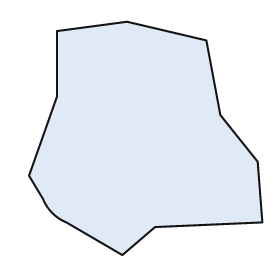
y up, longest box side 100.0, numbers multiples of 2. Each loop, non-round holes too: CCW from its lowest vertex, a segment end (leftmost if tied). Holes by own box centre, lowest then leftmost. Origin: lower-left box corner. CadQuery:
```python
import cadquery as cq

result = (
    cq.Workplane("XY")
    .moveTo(40.0, 0.0)
    .lineTo(54.0, 12.0)
    .lineTo(100.0, 14.0)
    .lineTo(98.0, 40.0)
    .lineTo(82.0, 60.0)
    .lineTo(76.0, 92.0)
    .lineTo(42.0, 100.0)
    .lineTo(12.0, 96.0)
    .lineTo(12.0, 68.0)
    .lineTo(0.0, 34.0)
    .lineTo(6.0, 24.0)
    .threePointArc((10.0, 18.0), (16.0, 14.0))
    .close()
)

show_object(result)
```